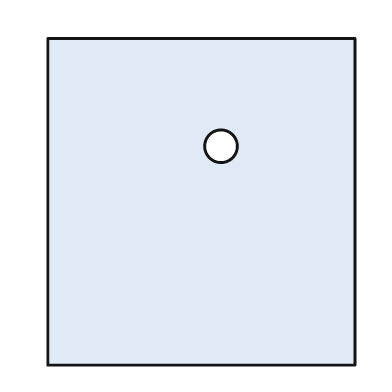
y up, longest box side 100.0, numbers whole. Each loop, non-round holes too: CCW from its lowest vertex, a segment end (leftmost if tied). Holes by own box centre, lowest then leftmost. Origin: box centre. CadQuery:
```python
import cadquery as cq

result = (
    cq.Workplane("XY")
    .moveTo(-47.0, -50.0)
    .lineTo(47.0, -50.0)
    .lineTo(47.0, 50.0)
    .lineTo(-47.0, 50.0)
    .close()
    .moveTo(6.0, 17.0)
    .circle(5.0)
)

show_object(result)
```